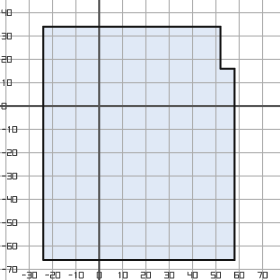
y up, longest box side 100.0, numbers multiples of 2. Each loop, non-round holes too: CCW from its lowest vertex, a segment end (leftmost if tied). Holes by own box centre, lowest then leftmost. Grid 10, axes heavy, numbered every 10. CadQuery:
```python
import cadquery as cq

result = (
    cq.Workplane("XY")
    .moveTo(-24.0, -66.0)
    .lineTo(58.0, -66.0)
    .lineTo(58.0, 16.0)
    .lineTo(52.0, 16.0)
    .lineTo(52.0, 34.0)
    .lineTo(-24.0, 34.0)
    .close()
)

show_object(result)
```